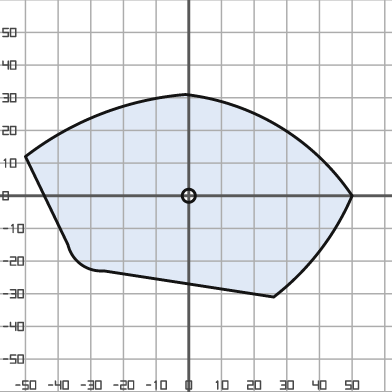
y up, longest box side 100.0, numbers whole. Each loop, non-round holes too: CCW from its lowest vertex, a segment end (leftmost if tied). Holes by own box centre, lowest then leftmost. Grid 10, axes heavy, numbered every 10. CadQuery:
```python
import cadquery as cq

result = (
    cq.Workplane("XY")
    .moveTo(26.0, -31.0)
    .threePointArc((40.0, -17.0), (50.0, 0.0))
    .threePointArc((28.0, 21.0), (-1.0, 31.0))
    .threePointArc((-27.0, 25.0), (-50.0, 12.0))
    .lineTo(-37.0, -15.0)
    .threePointArc((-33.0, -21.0), (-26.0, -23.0))
    .close()
    .moveTo(0.0, 0.0)
    .circle(2.0)
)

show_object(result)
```